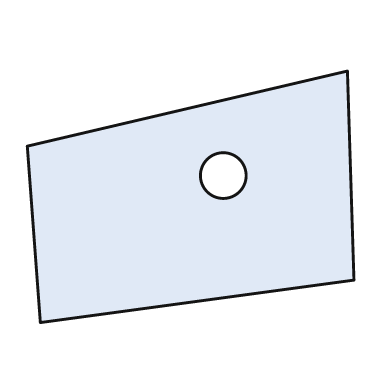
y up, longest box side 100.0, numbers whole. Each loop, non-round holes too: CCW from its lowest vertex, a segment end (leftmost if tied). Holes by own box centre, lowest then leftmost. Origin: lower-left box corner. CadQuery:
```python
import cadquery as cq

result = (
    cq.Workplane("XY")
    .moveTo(4.0, 0.0)
    .lineTo(100.0, 13.0)
    .lineTo(98.0, 77.0)
    .lineTo(0.0, 54.0)
    .close()
    .moveTo(60.0, 45.0)
    .circle(7.0)
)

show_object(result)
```